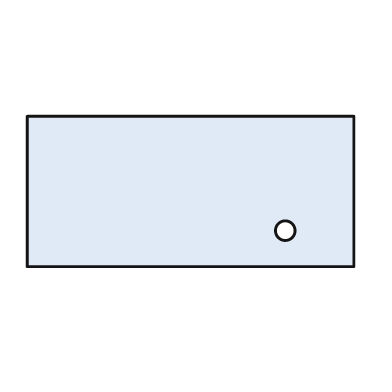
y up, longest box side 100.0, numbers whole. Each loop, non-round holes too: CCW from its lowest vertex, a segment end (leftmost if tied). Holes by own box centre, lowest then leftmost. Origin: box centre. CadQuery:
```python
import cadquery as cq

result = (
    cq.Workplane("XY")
    .moveTo(-50.0, -23.0)
    .lineTo(50.0, -23.0)
    .lineTo(50.0, 23.0)
    .lineTo(-50.0, 23.0)
    .close()
    .moveTo(29.0, -12.0)
    .circle(3.0)
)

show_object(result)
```